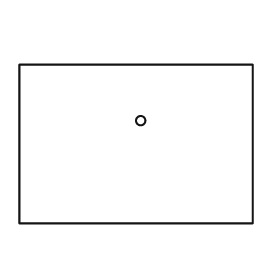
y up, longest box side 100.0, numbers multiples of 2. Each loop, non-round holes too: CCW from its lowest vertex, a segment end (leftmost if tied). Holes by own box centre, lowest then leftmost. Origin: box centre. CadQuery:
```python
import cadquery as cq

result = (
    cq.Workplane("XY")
    .moveTo(-50.0, -34.0)
    .lineTo(50.0, -34.0)
    .lineTo(50.0, 34.0)
    .lineTo(-50.0, 34.0)
    .close()
    .moveTo(2.0, 10.0)
    .circle(2.0)
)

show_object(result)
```